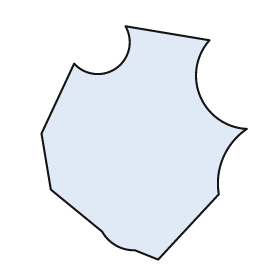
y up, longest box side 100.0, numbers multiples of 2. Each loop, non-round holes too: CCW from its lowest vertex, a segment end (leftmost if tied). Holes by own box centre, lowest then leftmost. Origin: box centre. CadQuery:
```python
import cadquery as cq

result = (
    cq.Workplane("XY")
    .moveTo(6.0, -50.0)
    .lineTo(32.0, -22.0)
    .threePointArc((34.0, -6.0), (44.0, 6.0))
    .threePointArc((24.0, 20.0), (28.0, 44.0))
    .lineTo(-8.0, 50.0)
    .threePointArc((-12.0, 32.0), (-30.0, 34.0))
    .lineTo(-44.0, 4.0)
    .lineTo(-40.0, -20.0)
    .lineTo(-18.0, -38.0)
    .threePointArc((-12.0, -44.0), (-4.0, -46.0))
    .close()
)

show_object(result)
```